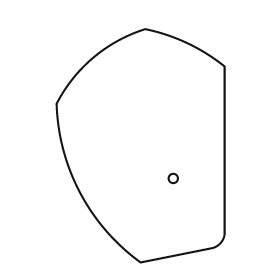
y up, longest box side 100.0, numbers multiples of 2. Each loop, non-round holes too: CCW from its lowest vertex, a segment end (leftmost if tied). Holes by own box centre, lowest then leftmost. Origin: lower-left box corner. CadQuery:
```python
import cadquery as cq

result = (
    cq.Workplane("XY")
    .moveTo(36.0, 0.0)
    .lineTo(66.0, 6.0)
    .threePointArc((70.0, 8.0), (72.0, 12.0))
    .lineTo(72.0, 84.0)
    .threePointArc((56.0, 94.0), (38.0, 100.0))
    .threePointArc((16.0, 88.0), (0.0, 68.0))
    .threePointArc((10.0, 30.0), (36.0, 0.0))
    .close()
    .moveTo(50.0, 36.0)
    .circle(2.0)
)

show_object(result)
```